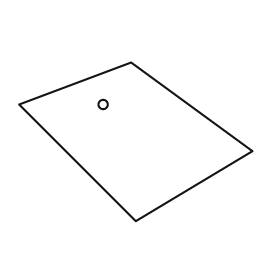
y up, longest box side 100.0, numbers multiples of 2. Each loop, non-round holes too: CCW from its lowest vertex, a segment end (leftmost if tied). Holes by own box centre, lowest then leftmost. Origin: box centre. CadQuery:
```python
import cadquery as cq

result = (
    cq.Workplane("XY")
    .moveTo(0.0, -34.0)
    .lineTo(50.0, -4.0)
    .lineTo(-2.0, 34.0)
    .lineTo(-50.0, 16.0)
    .close()
    .moveTo(-14.0, 16.0)
    .circle(2.0)
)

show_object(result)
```